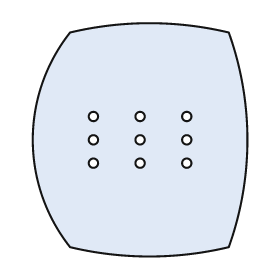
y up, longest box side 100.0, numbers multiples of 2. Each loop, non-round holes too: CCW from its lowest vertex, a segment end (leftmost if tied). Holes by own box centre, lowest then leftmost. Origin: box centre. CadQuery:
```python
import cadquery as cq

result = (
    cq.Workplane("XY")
    .moveTo(-30.0, -46.0)
    .threePointArc((4.0, -50.0), (38.0, -46.0))
    .threePointArc((46.0, 0.0), (38.0, 46.0))
    .threePointArc((4.0, 50.0), (-30.0, 46.0))
    .threePointArc((-46.0, 0.0), (-30.0, -46.0))
    .close()
    .moveTo(-20.0, -10.0)
    .circle(2.0)
    .moveTo(0.0, -10.0)
    .circle(2.0)
    .moveTo(20.0, -10.0)
    .circle(2.0)
    .moveTo(-20.0, 0.0)
    .circle(2.0)
    .moveTo(0.0, 0.0)
    .circle(2.0)
    .moveTo(20.0, 0.0)
    .circle(2.0)
    .moveTo(-20.0, 10.0)
    .circle(2.0)
    .moveTo(0.0, 10.0)
    .circle(2.0)
    .moveTo(20.0, 10.0)
    .circle(2.0)
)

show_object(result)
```